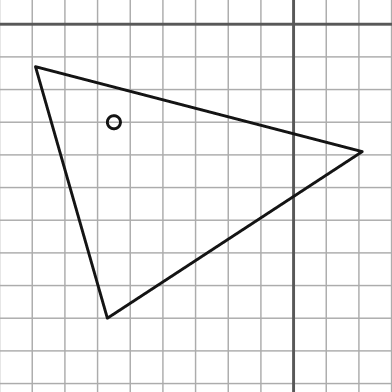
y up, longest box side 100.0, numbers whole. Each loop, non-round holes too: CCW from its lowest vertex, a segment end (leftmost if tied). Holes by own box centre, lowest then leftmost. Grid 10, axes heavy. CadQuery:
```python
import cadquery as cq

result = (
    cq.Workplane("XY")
    .moveTo(-57.0, -90.0)
    .lineTo(21.0, -39.0)
    .lineTo(-79.0, -13.0)
    .close()
    .moveTo(-55.0, -30.0)
    .circle(2.0)
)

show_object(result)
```